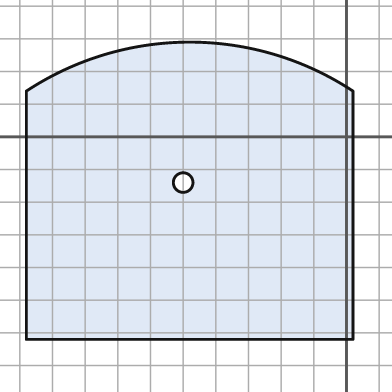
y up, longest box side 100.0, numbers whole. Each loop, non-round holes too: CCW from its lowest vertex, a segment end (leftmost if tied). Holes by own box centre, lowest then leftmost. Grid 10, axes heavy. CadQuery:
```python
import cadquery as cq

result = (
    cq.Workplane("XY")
    .moveTo(-98.0, -62.0)
    .lineTo(2.0, -62.0)
    .lineTo(2.0, 14.0)
    .threePointArc((-48.0, 29.0), (-98.0, 14.0))
    .close()
    .moveTo(-50.0, -14.0)
    .circle(3.0)
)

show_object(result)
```